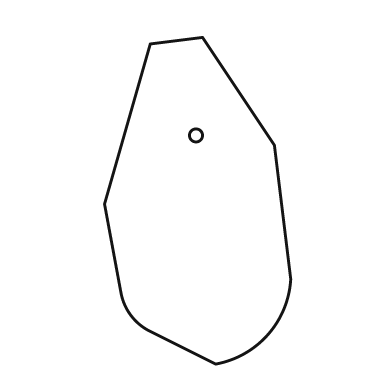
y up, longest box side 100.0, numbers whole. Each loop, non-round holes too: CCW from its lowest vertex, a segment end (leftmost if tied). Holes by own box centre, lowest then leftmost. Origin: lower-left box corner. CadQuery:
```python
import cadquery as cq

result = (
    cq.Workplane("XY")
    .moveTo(34.0, 0.0)
    .threePointArc((50.0, 9.0), (57.0, 26.0))
    .lineTo(52.0, 67.0)
    .lineTo(30.0, 100.0)
    .lineTo(14.0, 98.0)
    .lineTo(0.0, 49.0)
    .lineTo(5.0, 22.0)
    .threePointArc((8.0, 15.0), (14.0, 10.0))
    .close()
    .moveTo(28.0, 70.0)
    .circle(2.0)
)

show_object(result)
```